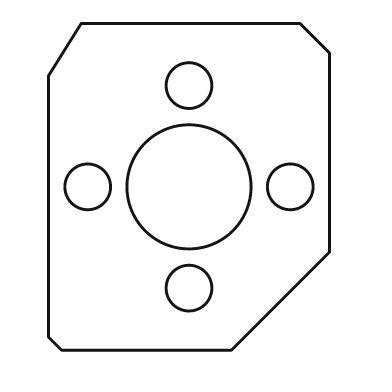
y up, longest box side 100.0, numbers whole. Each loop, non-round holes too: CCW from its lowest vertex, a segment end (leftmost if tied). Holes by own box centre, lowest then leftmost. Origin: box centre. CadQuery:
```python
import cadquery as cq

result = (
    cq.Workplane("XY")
    .moveTo(-39.0, -50.0)
    .lineTo(13.0, -50.0)
    .lineTo(43.0, -20.0)
    .lineTo(43.0, 41.0)
    .lineTo(34.0, 50.0)
    .lineTo(-33.0, 50.0)
    .lineTo(-43.0, 34.0)
    .lineTo(-43.0, -46.0)
    .close()
    .moveTo(0.0, -31.0)
    .circle(7.0)
    .moveTo(-31.0, 0.0)
    .circle(7.0)
    .moveTo(0.0, 0.0)
    .circle(19.0)
    .moveTo(31.0, 0.0)
    .circle(7.0)
    .moveTo(0.0, 31.0)
    .circle(7.0)
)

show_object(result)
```